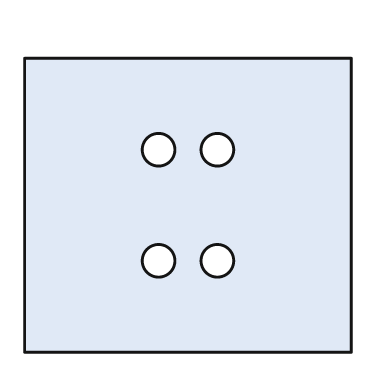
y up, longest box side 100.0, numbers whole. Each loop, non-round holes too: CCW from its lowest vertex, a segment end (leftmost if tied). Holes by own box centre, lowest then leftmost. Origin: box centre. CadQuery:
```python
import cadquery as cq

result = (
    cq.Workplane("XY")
    .moveTo(-50.0, -45.0)
    .lineTo(50.0, -45.0)
    .lineTo(50.0, 45.0)
    .lineTo(-50.0, 45.0)
    .close()
    .moveTo(-9.0, -17.0)
    .circle(5.0)
    .moveTo(9.0, -17.0)
    .circle(5.0)
    .moveTo(-9.0, 17.0)
    .circle(5.0)
    .moveTo(9.0, 17.0)
    .circle(5.0)
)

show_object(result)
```